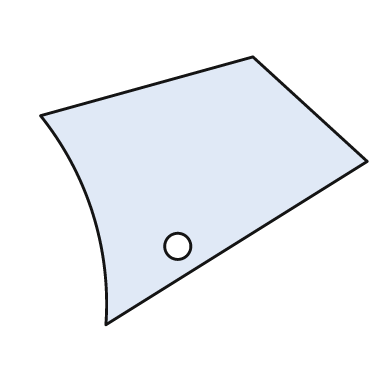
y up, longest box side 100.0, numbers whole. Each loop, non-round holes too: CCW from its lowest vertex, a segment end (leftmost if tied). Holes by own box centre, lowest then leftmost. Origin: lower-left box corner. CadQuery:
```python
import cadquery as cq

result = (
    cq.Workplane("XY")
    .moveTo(20.0, 0.0)
    .lineTo(100.0, 50.0)
    .lineTo(65.0, 82.0)
    .lineTo(0.0, 64.0)
    .threePointArc((16.0, 34.0), (20.0, 0.0))
    .close()
    .moveTo(42.0, 24.0)
    .circle(4.0)
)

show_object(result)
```